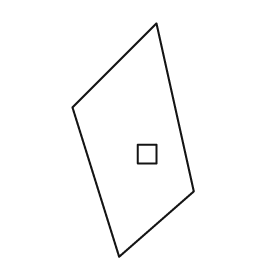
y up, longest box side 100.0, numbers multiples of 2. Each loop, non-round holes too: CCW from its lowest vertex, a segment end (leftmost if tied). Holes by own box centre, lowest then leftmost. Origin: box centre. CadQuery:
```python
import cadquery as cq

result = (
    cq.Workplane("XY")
    .moveTo(-6.0, -50.0)
    .lineTo(26.0, -22.0)
    .lineTo(10.0, 50.0)
    .lineTo(-26.0, 14.0)
    .close()
    .moveTo(2.0, -10.0)
    .lineTo(10.0, -10.0)
    .lineTo(10.0, -2.0)
    .lineTo(2.0, -2.0)
    .close()
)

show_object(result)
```